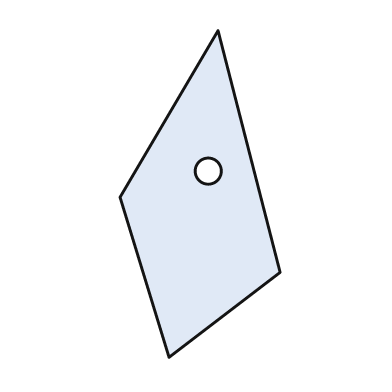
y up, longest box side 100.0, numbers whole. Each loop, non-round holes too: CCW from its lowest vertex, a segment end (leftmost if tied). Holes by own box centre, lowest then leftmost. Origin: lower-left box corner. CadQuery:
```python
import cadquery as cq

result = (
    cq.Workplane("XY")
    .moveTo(15.0, 0.0)
    .lineTo(49.0, 26.0)
    .lineTo(30.0, 100.0)
    .lineTo(0.0, 49.0)
    .close()
    .moveTo(27.0, 57.0)
    .circle(4.0)
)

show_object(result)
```